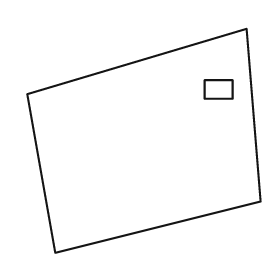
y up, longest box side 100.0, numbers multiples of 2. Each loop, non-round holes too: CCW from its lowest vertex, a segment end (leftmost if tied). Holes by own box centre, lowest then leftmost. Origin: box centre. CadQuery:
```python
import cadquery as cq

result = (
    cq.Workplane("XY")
    .moveTo(-38.0, -48.0)
    .lineTo(50.0, -26.0)
    .lineTo(44.0, 48.0)
    .lineTo(-50.0, 20.0)
    .close()
    .moveTo(26.0, 18.0)
    .lineTo(38.0, 18.0)
    .lineTo(38.0, 26.0)
    .lineTo(26.0, 26.0)
    .close()
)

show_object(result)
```